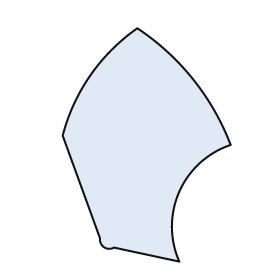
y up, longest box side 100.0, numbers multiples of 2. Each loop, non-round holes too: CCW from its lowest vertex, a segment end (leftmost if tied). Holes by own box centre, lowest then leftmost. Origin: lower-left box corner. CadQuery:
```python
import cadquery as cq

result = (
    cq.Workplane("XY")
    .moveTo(50.0, 0.0)
    .threePointArc((50.0, 30.0), (72.0, 50.0))
    .threePointArc((56.0, 78.0), (32.0, 100.0))
    .threePointArc((12.0, 80.0), (0.0, 54.0))
    .lineTo(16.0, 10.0)
    .threePointArc((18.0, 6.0), (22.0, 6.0))
    .close()
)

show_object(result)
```